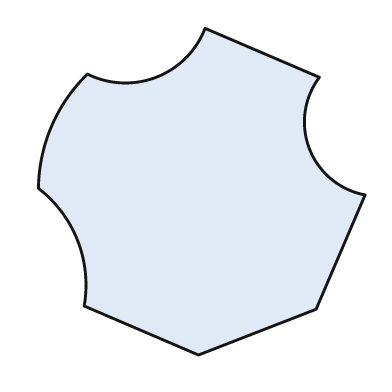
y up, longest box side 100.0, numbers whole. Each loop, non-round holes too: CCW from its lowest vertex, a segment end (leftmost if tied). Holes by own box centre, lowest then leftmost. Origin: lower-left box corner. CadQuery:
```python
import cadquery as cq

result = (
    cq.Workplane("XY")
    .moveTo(49.0, 0.0)
    .lineTo(85.0, 14.0)
    .lineTo(100.0, 49.0)
    .threePointArc((83.0, 63.0), (86.0, 85.0))
    .lineTo(51.0, 100.0)
    .threePointArc((36.0, 85.0), (15.0, 86.0))
    .threePointArc((4.0, 70.0), (0.0, 51.0))
    .threePointArc((12.0, 35.0), (14.0, 15.0))
    .close()
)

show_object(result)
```